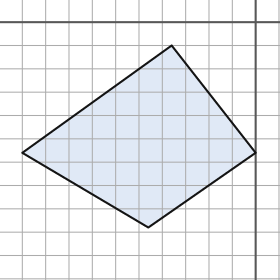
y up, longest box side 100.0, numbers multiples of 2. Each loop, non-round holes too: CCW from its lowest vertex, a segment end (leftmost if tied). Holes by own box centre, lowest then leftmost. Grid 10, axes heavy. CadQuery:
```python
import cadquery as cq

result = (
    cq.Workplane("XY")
    .moveTo(-46.0, -88.0)
    .lineTo(0.0, -56.0)
    .lineTo(-36.0, -10.0)
    .lineTo(-100.0, -56.0)
    .close()
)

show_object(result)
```